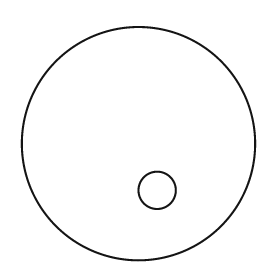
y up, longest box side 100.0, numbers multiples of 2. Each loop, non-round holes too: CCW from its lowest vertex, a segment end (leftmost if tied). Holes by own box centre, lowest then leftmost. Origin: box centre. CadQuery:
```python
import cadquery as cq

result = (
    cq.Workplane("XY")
    .moveTo(0.0, 0.0)
    .circle(50.0)
    .moveTo(8.0, -20.0)
    .circle(8.0)
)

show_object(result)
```